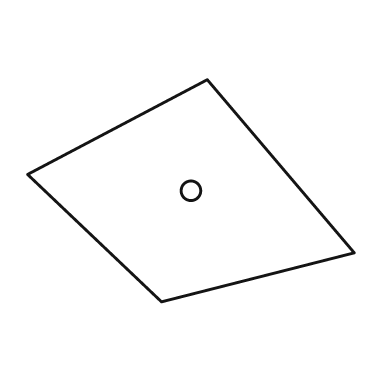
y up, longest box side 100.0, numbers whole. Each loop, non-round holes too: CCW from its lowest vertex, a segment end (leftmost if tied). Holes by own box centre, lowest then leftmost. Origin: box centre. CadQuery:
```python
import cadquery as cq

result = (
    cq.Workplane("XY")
    .moveTo(-9.0, -34.0)
    .lineTo(50.0, -19.0)
    .lineTo(5.0, 34.0)
    .lineTo(-50.0, 5.0)
    .close()
    .moveTo(0.0, 0.0)
    .circle(3.0)
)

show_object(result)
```